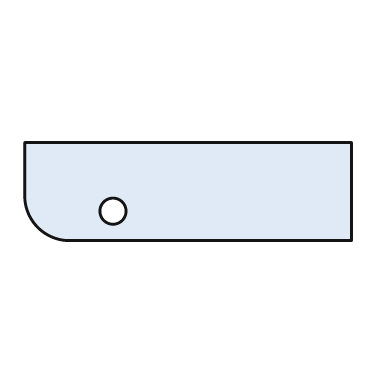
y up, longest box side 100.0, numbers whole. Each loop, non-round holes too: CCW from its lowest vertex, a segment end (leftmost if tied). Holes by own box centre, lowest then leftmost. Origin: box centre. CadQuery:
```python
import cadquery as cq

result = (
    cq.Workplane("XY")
    .moveTo(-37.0, -15.0)
    .lineTo(50.0, -15.0)
    .lineTo(50.0, 15.0)
    .lineTo(-50.0, 15.0)
    .lineTo(-50.0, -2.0)
    .threePointArc((-46.0, -11.0), (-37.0, -15.0))
    .close()
    .moveTo(-23.0, -6.0)
    .circle(4.0)
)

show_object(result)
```